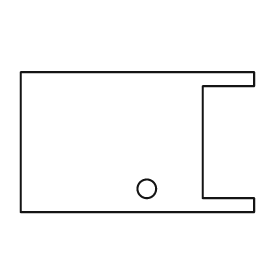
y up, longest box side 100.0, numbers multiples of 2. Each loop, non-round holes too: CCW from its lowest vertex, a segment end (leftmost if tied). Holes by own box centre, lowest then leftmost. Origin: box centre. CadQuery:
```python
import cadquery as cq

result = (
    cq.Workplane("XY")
    .moveTo(-50.0, -30.0)
    .lineTo(50.0, -30.0)
    .lineTo(50.0, -24.0)
    .lineTo(28.0, -24.0)
    .lineTo(28.0, 24.0)
    .lineTo(50.0, 24.0)
    .lineTo(50.0, 30.0)
    .lineTo(-50.0, 30.0)
    .close()
    .moveTo(4.0, -20.0)
    .circle(4.0)
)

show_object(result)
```